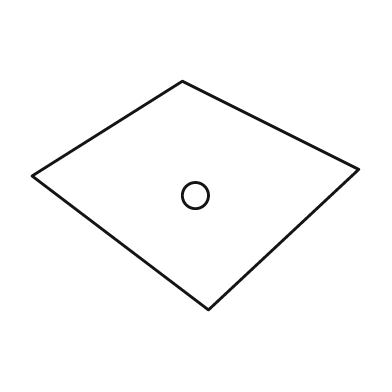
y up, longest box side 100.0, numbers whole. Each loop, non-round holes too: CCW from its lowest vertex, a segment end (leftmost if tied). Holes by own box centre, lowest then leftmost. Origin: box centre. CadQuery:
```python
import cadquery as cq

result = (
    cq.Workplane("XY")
    .moveTo(4.0, -35.0)
    .lineTo(50.0, 8.0)
    .lineTo(-4.0, 35.0)
    .lineTo(-50.0, 6.0)
    .close()
    .moveTo(0.0, 0.0)
    .circle(4.0)
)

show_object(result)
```